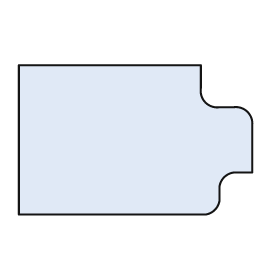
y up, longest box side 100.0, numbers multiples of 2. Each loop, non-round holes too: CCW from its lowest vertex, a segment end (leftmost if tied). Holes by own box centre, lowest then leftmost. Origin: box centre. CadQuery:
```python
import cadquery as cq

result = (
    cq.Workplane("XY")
    .moveTo(-50.0, -32.0)
    .lineTo(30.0, -32.0)
    .threePointArc((34.0, -30.0), (36.0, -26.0))
    .lineTo(36.0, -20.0)
    .threePointArc((38.0, -16.0), (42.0, -14.0))
    .lineTo(50.0, -14.0)
    .lineTo(50.0, 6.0)
    .threePointArc((48.0, 12.0), (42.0, 14.0))
    .lineTo(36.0, 14.0)
    .threePointArc((30.0, 16.0), (28.0, 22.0))
    .lineTo(28.0, 32.0)
    .lineTo(-50.0, 32.0)
    .close()
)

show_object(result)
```